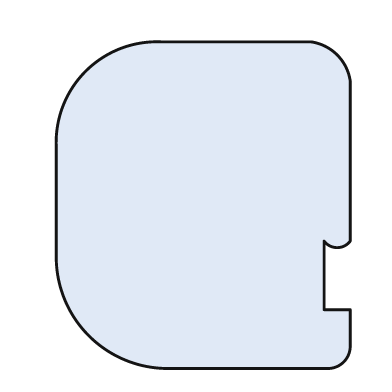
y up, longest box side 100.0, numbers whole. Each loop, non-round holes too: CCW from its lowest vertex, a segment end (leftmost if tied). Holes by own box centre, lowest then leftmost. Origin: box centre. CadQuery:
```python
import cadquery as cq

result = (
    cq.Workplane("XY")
    .moveTo(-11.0, -50.0)
    .lineTo(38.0, -50.0)
    .threePointArc((43.0, -48.0), (45.0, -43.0))
    .lineTo(45.0, -32.0)
    .lineTo(37.0, -32.0)
    .lineTo(37.0, -11.0)
    .threePointArc((41.0, -13.0), (45.0, -11.0))
    .lineTo(45.0, 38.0)
    .threePointArc((41.0, 46.0), (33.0, 50.0))
    .lineTo(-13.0, 50.0)
    .threePointArc((-36.0, 41.0), (-45.0, 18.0))
    .lineTo(-45.0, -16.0)
    .threePointArc((-35.0, -40.0), (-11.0, -50.0))
    .close()
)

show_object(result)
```